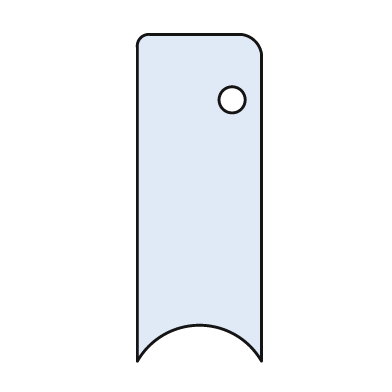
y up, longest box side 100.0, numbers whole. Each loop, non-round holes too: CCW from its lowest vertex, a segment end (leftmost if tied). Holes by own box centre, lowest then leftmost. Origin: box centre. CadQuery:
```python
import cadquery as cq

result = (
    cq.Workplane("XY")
    .moveTo(-19.0, -50.0)
    .threePointArc((0.0, -39.0), (19.0, -50.0))
    .lineTo(19.0, 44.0)
    .threePointArc((17.0, 48.0), (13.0, 50.0))
    .lineTo(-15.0, 50.0)
    .threePointArc((-18.0, 49.0), (-19.0, 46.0))
    .close()
    .moveTo(10.0, 30.0)
    .circle(4.0)
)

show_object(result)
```